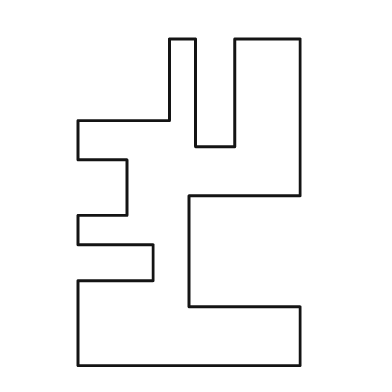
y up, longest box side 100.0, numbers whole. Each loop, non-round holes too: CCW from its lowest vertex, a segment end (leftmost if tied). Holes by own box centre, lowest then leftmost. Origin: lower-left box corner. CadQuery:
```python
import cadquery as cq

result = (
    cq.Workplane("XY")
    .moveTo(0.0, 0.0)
    .lineTo(68.0, 0.0)
    .lineTo(68.0, 18.0)
    .lineTo(34.0, 18.0)
    .lineTo(34.0, 52.0)
    .lineTo(68.0, 52.0)
    .lineTo(68.0, 100.0)
    .lineTo(48.0, 100.0)
    .lineTo(48.0, 67.0)
    .lineTo(36.0, 67.0)
    .lineTo(36.0, 100.0)
    .lineTo(28.0, 100.0)
    .lineTo(28.0, 75.0)
    .lineTo(0.0, 75.0)
    .lineTo(0.0, 63.0)
    .lineTo(15.0, 63.0)
    .lineTo(15.0, 46.0)
    .lineTo(0.0, 46.0)
    .lineTo(0.0, 37.0)
    .lineTo(23.0, 37.0)
    .lineTo(23.0, 26.0)
    .lineTo(0.0, 26.0)
    .close()
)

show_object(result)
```